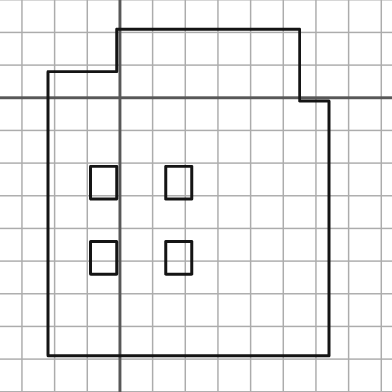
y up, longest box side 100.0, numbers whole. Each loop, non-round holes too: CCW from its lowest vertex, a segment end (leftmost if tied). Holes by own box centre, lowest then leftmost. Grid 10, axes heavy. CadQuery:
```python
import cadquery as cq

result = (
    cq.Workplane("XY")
    .moveTo(-22.0, -79.0)
    .lineTo(64.0, -79.0)
    .lineTo(64.0, -1.0)
    .lineTo(55.0, -1.0)
    .lineTo(55.0, 21.0)
    .lineTo(-1.0, 21.0)
    .lineTo(-1.0, 8.0)
    .lineTo(-22.0, 8.0)
    .close()
    .moveTo(-9.0, -54.0)
    .lineTo(-1.0, -54.0)
    .lineTo(-1.0, -44.0)
    .lineTo(-9.0, -44.0)
    .close()
    .moveTo(14.0, -54.0)
    .lineTo(22.0, -54.0)
    .lineTo(22.0, -44.0)
    .lineTo(14.0, -44.0)
    .close()
    .moveTo(-9.0, -31.0)
    .lineTo(-1.0, -31.0)
    .lineTo(-1.0, -21.0)
    .lineTo(-9.0, -21.0)
    .close()
    .moveTo(14.0, -31.0)
    .lineTo(22.0, -31.0)
    .lineTo(22.0, -21.0)
    .lineTo(14.0, -21.0)
    .close()
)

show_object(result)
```